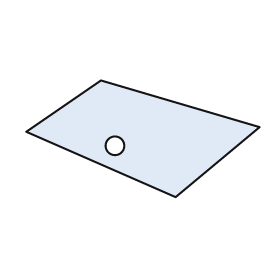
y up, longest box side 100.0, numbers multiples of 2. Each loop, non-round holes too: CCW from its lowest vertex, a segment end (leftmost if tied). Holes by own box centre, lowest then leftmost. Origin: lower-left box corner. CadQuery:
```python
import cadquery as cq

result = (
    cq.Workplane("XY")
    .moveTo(64.0, 0.0)
    .lineTo(100.0, 30.0)
    .lineTo(32.0, 50.0)
    .lineTo(0.0, 28.0)
    .close()
    .moveTo(38.0, 22.0)
    .circle(4.0)
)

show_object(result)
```